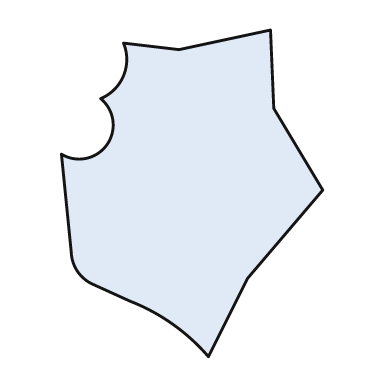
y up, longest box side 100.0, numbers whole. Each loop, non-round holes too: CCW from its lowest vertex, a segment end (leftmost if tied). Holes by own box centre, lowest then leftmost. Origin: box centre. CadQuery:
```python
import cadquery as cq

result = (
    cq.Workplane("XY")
    .moveTo(5.0, -50.0)
    .lineTo(17.0, -26.0)
    .lineTo(40.0, 1.0)
    .lineTo(25.0, 26.0)
    .lineTo(24.0, 50.0)
    .lineTo(-4.0, 44.0)
    .lineTo(-21.0, 46.0)
    .threePointArc((-21.0, 36.0), (-28.0, 29.0))
    .threePointArc((-26.0, 15.0), (-40.0, 12.0))
    .lineTo(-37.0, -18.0)
    .threePointArc((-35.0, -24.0), (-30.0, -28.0))
    .lineTo(-19.0, -33.0)
    .threePointArc((-6.0, -40.0), (5.0, -50.0))
    .close()
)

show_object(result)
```